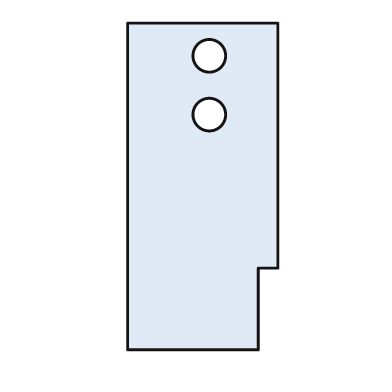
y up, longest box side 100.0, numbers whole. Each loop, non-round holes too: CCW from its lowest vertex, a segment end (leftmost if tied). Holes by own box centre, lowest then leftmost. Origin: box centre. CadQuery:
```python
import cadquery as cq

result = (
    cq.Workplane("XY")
    .moveTo(-23.0, -50.0)
    .lineTo(17.0, -50.0)
    .lineTo(17.0, -25.0)
    .lineTo(23.0, -25.0)
    .lineTo(23.0, 50.0)
    .lineTo(-23.0, 50.0)
    .close()
    .moveTo(2.0, 22.0)
    .circle(5.0)
    .moveTo(2.0, 40.0)
    .circle(5.0)
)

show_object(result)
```